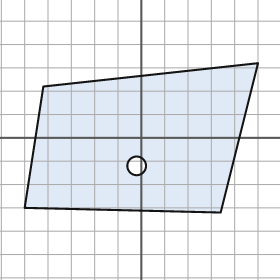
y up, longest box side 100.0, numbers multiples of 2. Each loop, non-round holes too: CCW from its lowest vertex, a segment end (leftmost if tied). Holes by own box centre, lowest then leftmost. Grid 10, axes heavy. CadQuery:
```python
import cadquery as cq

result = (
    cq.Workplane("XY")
    .moveTo(34.0, -32.0)
    .lineTo(50.0, 32.0)
    .lineTo(-42.0, 22.0)
    .lineTo(-50.0, -30.0)
    .close()
    .moveTo(-2.0, -12.0)
    .circle(4.0)
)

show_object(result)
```